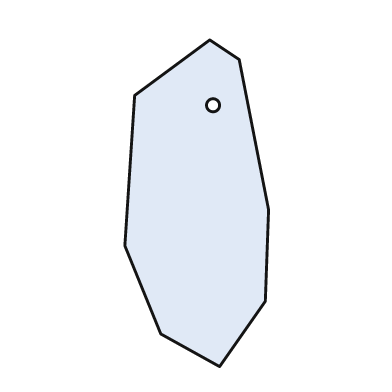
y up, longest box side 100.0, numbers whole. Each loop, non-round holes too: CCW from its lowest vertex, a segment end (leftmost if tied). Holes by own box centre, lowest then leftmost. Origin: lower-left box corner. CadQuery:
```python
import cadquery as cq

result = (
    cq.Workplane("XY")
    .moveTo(29.0, 0.0)
    .lineTo(43.0, 20.0)
    .lineTo(44.0, 48.0)
    .lineTo(35.0, 94.0)
    .lineTo(26.0, 100.0)
    .lineTo(3.0, 83.0)
    .lineTo(0.0, 37.0)
    .lineTo(11.0, 10.0)
    .close()
    .moveTo(27.0, 80.0)
    .circle(2.0)
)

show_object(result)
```